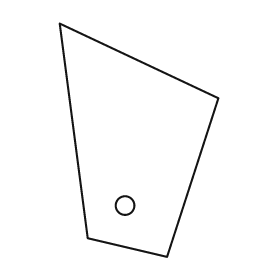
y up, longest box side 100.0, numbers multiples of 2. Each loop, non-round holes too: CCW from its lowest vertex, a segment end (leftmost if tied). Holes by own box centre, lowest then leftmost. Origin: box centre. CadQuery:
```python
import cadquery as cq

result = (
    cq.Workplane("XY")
    .moveTo(12.0, -50.0)
    .lineTo(34.0, 18.0)
    .lineTo(-34.0, 50.0)
    .lineTo(-22.0, -42.0)
    .close()
    .moveTo(-6.0, -28.0)
    .circle(4.0)
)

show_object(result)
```